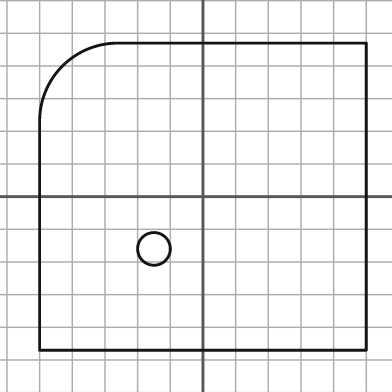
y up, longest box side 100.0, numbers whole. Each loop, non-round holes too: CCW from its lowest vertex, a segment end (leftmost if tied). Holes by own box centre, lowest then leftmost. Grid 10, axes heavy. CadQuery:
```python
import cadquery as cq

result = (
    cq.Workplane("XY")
    .moveTo(-50.0, -47.0)
    .lineTo(50.0, -47.0)
    .lineTo(50.0, 47.0)
    .lineTo(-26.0, 47.0)
    .threePointArc((-43.0, 40.0), (-50.0, 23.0))
    .close()
    .moveTo(-15.0, -16.0)
    .circle(5.0)
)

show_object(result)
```